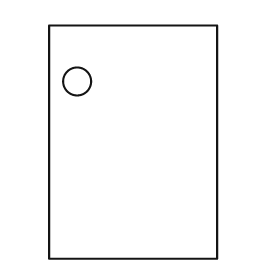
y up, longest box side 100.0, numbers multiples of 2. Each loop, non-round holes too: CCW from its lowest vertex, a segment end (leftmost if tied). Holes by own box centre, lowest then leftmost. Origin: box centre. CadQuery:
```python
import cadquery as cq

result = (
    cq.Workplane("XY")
    .moveTo(-36.0, -50.0)
    .lineTo(36.0, -50.0)
    .lineTo(36.0, 50.0)
    .lineTo(-36.0, 50.0)
    .close()
    .moveTo(-24.0, 26.0)
    .circle(6.0)
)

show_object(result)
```